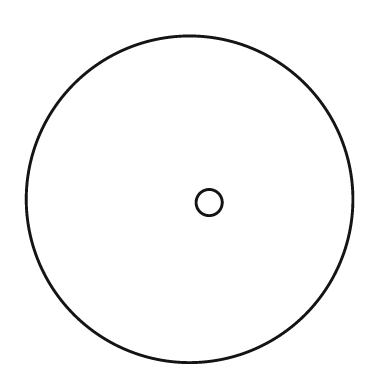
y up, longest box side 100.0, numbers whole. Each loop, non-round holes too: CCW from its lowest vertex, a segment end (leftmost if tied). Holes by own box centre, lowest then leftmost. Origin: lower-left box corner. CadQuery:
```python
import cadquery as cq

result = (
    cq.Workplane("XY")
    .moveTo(50.0, 50.0)
    .circle(50.0)
    .moveTo(56.0, 49.0)
    .circle(4.0)
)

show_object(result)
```